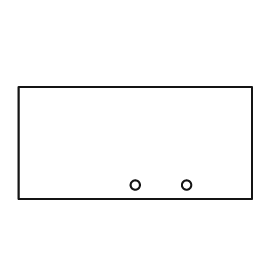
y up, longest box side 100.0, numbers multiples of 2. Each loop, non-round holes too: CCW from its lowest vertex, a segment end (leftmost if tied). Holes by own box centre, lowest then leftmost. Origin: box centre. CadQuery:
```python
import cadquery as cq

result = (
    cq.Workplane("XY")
    .moveTo(-50.0, -24.0)
    .lineTo(50.0, -24.0)
    .lineTo(50.0, 24.0)
    .lineTo(-50.0, 24.0)
    .close()
    .moveTo(0.0, -18.0)
    .circle(2.0)
    .moveTo(22.0, -18.0)
    .circle(2.0)
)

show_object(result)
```